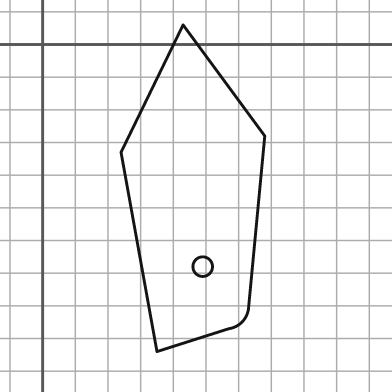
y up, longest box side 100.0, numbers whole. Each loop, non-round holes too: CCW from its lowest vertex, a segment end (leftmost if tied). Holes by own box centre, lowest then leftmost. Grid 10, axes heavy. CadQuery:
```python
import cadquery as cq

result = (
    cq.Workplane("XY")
    .moveTo(35.0, -94.0)
    .lineTo(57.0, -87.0)
    .threePointArc((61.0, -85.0), (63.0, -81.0))
    .lineTo(68.0, -28.0)
    .lineTo(43.0, 6.0)
    .lineTo(24.0, -33.0)
    .close()
    .moveTo(49.0, -68.0)
    .circle(3.0)
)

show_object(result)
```